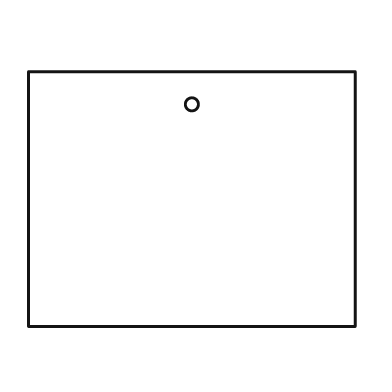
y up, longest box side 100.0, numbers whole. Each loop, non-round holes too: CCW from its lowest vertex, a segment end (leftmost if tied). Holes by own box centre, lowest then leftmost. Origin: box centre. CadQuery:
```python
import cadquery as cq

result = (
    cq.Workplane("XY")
    .moveTo(-50.0, -39.0)
    .lineTo(50.0, -39.0)
    .lineTo(50.0, 39.0)
    .lineTo(-50.0, 39.0)
    .close()
    .moveTo(0.0, 29.0)
    .circle(2.0)
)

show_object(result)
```